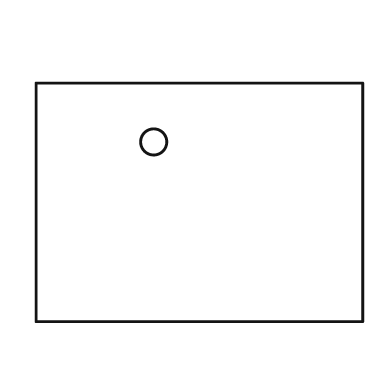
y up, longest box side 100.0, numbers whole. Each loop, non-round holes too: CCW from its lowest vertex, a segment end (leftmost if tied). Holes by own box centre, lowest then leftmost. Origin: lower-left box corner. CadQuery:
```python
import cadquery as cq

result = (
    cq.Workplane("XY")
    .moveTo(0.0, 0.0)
    .lineTo(100.0, 0.0)
    .lineTo(100.0, 73.0)
    .lineTo(0.0, 73.0)
    .close()
    .moveTo(36.0, 55.0)
    .circle(4.0)
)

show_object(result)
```